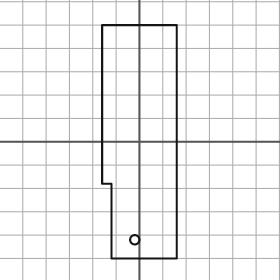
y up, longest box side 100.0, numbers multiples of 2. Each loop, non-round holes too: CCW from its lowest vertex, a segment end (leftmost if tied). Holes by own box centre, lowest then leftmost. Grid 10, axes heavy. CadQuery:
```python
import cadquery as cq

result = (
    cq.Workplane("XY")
    .moveTo(-12.0, -50.0)
    .lineTo(16.0, -50.0)
    .lineTo(16.0, 50.0)
    .lineTo(-16.0, 50.0)
    .lineTo(-16.0, -18.0)
    .lineTo(-12.0, -18.0)
    .close()
    .moveTo(-2.0, -42.0)
    .circle(2.0)
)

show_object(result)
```